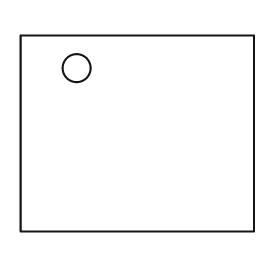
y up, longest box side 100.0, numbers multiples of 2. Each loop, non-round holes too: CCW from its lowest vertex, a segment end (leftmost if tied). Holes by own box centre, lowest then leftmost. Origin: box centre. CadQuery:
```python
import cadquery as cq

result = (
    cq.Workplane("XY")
    .moveTo(-50.0, -42.0)
    .lineTo(50.0, -42.0)
    .lineTo(50.0, 42.0)
    .lineTo(-50.0, 42.0)
    .close()
    .moveTo(-26.0, 28.0)
    .circle(6.0)
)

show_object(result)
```